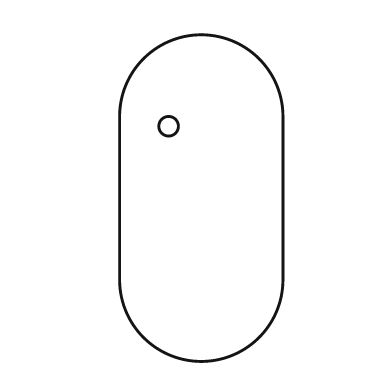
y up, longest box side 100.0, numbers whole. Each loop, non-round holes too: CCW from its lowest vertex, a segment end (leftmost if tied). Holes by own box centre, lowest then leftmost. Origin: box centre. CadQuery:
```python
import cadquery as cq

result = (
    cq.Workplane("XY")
    .moveTo(-25.0, -25.0)
    .threePointArc((0.0, -50.0), (25.0, -25.0))
    .lineTo(25.0, 25.0)
    .threePointArc((0.0, 50.0), (-25.0, 25.0))
    .close()
    .moveTo(-10.0, 22.0)
    .circle(3.0)
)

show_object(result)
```